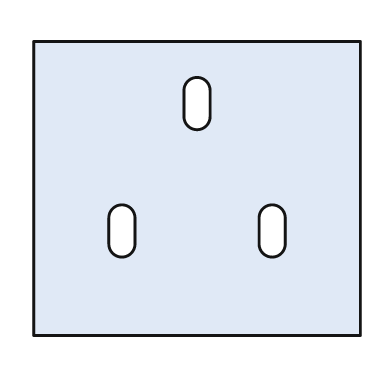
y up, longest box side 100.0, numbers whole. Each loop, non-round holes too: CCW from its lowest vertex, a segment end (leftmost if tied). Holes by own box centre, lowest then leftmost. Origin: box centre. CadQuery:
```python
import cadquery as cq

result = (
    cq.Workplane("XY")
    .moveTo(-50.0, -45.0)
    .lineTo(50.0, -45.0)
    .lineTo(50.0, 45.0)
    .lineTo(-50.0, 45.0)
    .close()
    .moveTo(-27.0, -17.0)
    .threePointArc((-23.0, -21.0), (-19.0, -17.0))
    .lineTo(-19.0, -9.0)
    .threePointArc((-23.0, -5.0), (-27.0, -9.0))
    .close()
    .moveTo(19.0, -17.0)
    .threePointArc((23.0, -21.0), (27.0, -17.0))
    .lineTo(27.0, -9.0)
    .threePointArc((23.0, -5.0), (19.0, -9.0))
    .close()
    .moveTo(-4.0, 22.0)
    .threePointArc((0.0, 18.0), (4.0, 22.0))
    .lineTo(4.0, 30.0)
    .threePointArc((0.0, 34.0), (-4.0, 30.0))
    .close()
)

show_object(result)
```